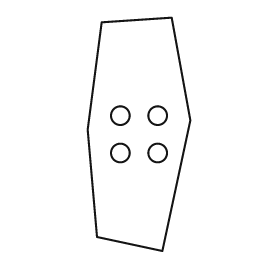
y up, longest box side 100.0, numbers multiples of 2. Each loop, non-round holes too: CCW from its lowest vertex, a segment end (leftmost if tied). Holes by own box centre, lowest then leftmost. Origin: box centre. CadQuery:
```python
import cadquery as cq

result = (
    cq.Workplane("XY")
    .moveTo(10.0, -50.0)
    .lineTo(22.0, 6.0)
    .lineTo(14.0, 50.0)
    .lineTo(-16.0, 48.0)
    .lineTo(-22.0, 2.0)
    .lineTo(-18.0, -44.0)
    .close()
    .moveTo(-8.0, -8.0)
    .circle(4.0)
    .moveTo(8.0, -8.0)
    .circle(4.0)
    .moveTo(-8.0, 8.0)
    .circle(4.0)
    .moveTo(8.0, 8.0)
    .circle(4.0)
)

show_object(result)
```